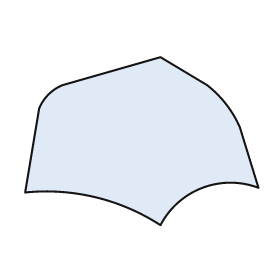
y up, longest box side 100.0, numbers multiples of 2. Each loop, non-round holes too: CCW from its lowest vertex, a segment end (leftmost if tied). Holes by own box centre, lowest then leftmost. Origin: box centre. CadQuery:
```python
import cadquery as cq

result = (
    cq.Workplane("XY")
    .moveTo(8.0, -36.0)
    .threePointArc((26.0, -20.0), (50.0, -20.0))
    .lineTo(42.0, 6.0)
    .threePointArc((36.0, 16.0), (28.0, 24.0))
    .lineTo(8.0, 36.0)
    .lineTo(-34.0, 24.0)
    .threePointArc((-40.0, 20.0), (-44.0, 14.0))
    .lineTo(-50.0, -22.0)
    .threePointArc((-20.0, -24.0), (8.0, -36.0))
    .close()
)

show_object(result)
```